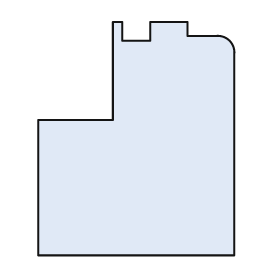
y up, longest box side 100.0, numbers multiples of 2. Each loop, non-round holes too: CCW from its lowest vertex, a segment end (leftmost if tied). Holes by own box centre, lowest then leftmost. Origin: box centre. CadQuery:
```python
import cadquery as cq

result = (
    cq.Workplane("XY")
    .moveTo(-42.0, -50.0)
    .lineTo(42.0, -50.0)
    .lineTo(42.0, 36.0)
    .threePointArc((40.0, 42.0), (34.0, 44.0))
    .lineTo(22.0, 44.0)
    .lineTo(22.0, 50.0)
    .lineTo(6.0, 50.0)
    .lineTo(6.0, 42.0)
    .lineTo(-6.0, 42.0)
    .lineTo(-6.0, 50.0)
    .lineTo(-10.0, 50.0)
    .lineTo(-10.0, 8.0)
    .lineTo(-42.0, 8.0)
    .close()
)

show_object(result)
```